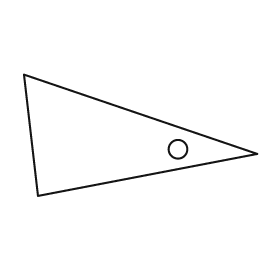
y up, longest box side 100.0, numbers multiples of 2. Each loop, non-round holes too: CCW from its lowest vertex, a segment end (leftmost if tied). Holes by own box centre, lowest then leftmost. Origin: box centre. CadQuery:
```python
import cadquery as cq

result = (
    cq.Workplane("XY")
    .moveTo(-44.0, -26.0)
    .lineTo(50.0, -8.0)
    .lineTo(-50.0, 26.0)
    .close()
    .moveTo(16.0, -6.0)
    .circle(4.0)
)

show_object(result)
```